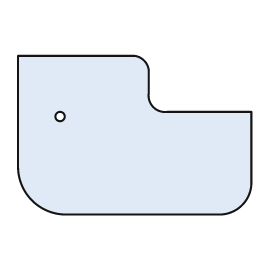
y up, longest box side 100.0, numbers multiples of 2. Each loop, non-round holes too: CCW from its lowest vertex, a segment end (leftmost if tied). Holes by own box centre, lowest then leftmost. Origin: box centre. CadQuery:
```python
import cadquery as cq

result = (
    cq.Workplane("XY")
    .moveTo(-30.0, -34.0)
    .lineTo(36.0, -34.0)
    .threePointArc((46.0, -30.0), (50.0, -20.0))
    .lineTo(50.0, 10.0)
    .lineTo(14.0, 10.0)
    .threePointArc((8.0, 12.0), (6.0, 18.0))
    .lineTo(6.0, 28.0)
    .threePointArc((4.0, 32.0), (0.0, 34.0))
    .lineTo(-50.0, 34.0)
    .lineTo(-50.0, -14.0)
    .threePointArc((-44.0, -28.0), (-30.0, -34.0))
    .close()
    .moveTo(-32.0, 8.0)
    .circle(2.0)
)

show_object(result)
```